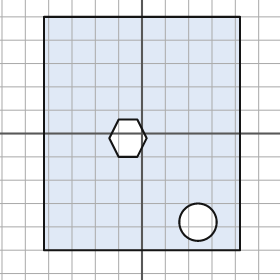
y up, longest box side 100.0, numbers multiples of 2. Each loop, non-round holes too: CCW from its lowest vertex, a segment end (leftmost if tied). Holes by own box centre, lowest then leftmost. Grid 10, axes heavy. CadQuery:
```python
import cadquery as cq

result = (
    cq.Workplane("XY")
    .moveTo(-42.0, -50.0)
    .lineTo(42.0, -50.0)
    .lineTo(42.0, 50.0)
    .lineTo(-42.0, 50.0)
    .close()
    .moveTo(24.0, -38.0)
    .circle(8.0)
    .moveTo(-10.0, -10.0)
    .lineTo(-2.0, -10.0)
    .lineTo(2.0, -2.0)
    .lineTo(-2.0, 6.0)
    .lineTo(-10.0, 6.0)
    .lineTo(-14.0, -2.0)
    .close()
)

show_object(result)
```